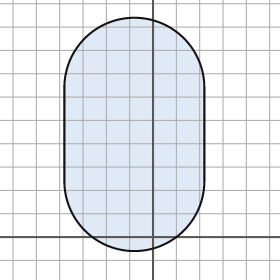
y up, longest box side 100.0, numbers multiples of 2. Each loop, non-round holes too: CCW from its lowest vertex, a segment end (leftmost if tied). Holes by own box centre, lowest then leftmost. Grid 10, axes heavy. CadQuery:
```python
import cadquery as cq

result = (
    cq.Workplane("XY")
    .moveTo(-38.0, 24.0)
    .threePointArc((-8.0, -6.0), (22.0, 24.0))
    .lineTo(22.0, 64.0)
    .threePointArc((-8.0, 94.0), (-38.0, 64.0))
    .close()
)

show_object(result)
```